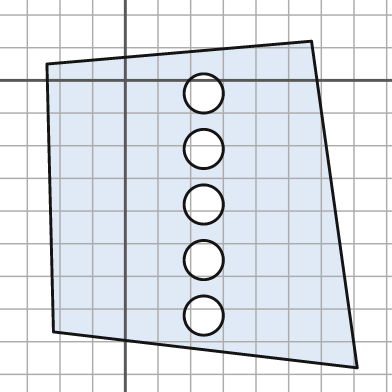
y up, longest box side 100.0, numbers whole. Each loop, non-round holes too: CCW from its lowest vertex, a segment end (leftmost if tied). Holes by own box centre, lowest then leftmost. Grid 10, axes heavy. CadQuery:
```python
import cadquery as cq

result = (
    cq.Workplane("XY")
    .moveTo(71.0, -88.0)
    .lineTo(57.0, 12.0)
    .lineTo(-24.0, 5.0)
    .lineTo(-22.0, -77.0)
    .close()
    .moveTo(24.0, -72.0)
    .circle(6.0)
    .moveTo(24.0, -55.0)
    .circle(6.0)
    .moveTo(24.0, -38.0)
    .circle(6.0)
    .moveTo(24.0, -21.0)
    .circle(6.0)
    .moveTo(24.0, -4.0)
    .circle(6.0)
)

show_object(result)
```